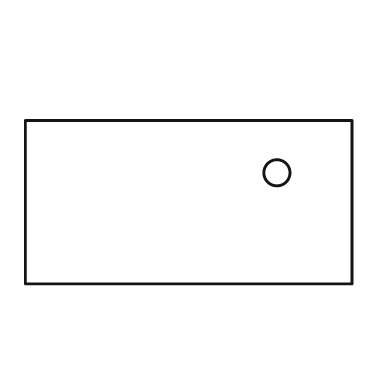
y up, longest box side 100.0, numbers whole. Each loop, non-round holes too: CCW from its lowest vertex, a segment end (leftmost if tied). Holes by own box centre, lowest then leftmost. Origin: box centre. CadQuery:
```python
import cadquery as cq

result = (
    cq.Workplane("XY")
    .moveTo(-50.0, -25.0)
    .lineTo(50.0, -25.0)
    .lineTo(50.0, 25.0)
    .lineTo(-50.0, 25.0)
    .close()
    .moveTo(27.0, 9.0)
    .circle(4.0)
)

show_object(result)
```